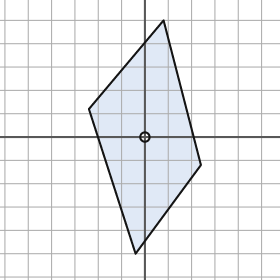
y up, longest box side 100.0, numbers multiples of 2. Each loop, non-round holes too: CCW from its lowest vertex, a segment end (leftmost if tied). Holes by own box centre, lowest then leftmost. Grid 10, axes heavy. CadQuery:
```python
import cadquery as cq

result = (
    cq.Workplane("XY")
    .moveTo(-4.0, -50.0)
    .lineTo(24.0, -12.0)
    .lineTo(8.0, 50.0)
    .lineTo(-24.0, 12.0)
    .close()
    .moveTo(0.0, 0.0)
    .circle(2.0)
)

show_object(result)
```